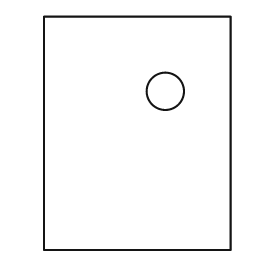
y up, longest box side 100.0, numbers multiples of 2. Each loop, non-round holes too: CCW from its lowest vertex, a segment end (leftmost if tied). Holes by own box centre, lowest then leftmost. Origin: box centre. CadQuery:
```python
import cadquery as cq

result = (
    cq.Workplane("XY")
    .moveTo(-40.0, -50.0)
    .lineTo(40.0, -50.0)
    .lineTo(40.0, 50.0)
    .lineTo(-40.0, 50.0)
    .close()
    .moveTo(12.0, 18.0)
    .circle(8.0)
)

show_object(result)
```